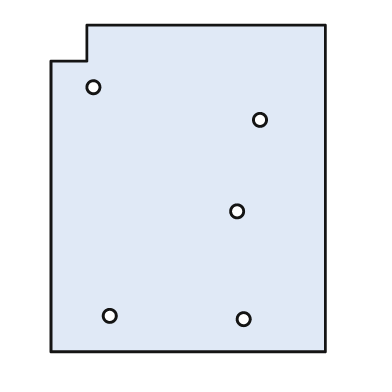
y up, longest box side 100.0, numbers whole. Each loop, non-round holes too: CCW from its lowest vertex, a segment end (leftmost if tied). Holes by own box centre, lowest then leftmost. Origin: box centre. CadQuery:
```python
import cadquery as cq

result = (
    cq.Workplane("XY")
    .moveTo(-42.0, -50.0)
    .lineTo(42.0, -50.0)
    .lineTo(42.0, 50.0)
    .lineTo(-31.0, 50.0)
    .lineTo(-31.0, 39.0)
    .lineTo(-42.0, 39.0)
    .close()
    .moveTo(17.0, -40.0)
    .circle(2.0)
    .moveTo(-24.0, -39.0)
    .circle(2.0)
    .moveTo(15.0, -7.0)
    .circle(2.0)
    .moveTo(22.0, 21.0)
    .circle(2.0)
    .moveTo(-29.0, 31.0)
    .circle(2.0)
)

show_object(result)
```